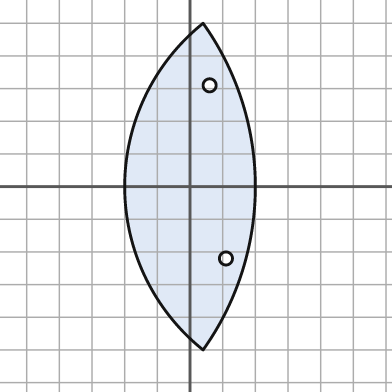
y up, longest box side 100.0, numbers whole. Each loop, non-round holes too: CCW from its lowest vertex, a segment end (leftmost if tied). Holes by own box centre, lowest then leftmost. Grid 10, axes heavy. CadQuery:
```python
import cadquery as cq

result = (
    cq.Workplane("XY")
    .moveTo(4.0, -50.0)
    .threePointArc((20.0, 0.0), (4.0, 50.0))
    .threePointArc((-20.0, 0.0), (4.0, -50.0))
    .close()
    .moveTo(11.0, -22.0)
    .circle(2.0)
    .moveTo(6.0, 31.0)
    .circle(2.0)
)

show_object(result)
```